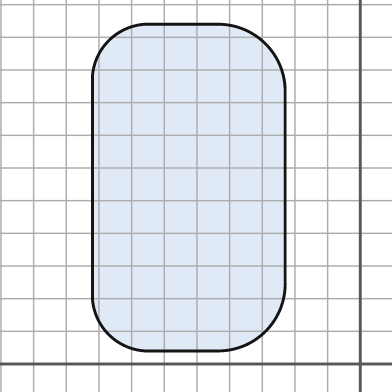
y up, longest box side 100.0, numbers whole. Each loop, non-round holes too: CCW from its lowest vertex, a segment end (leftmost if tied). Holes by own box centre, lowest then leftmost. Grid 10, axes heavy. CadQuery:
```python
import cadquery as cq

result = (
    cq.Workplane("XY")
    .moveTo(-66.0, 4.0)
    .lineTo(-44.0, 4.0)
    .threePointArc((-29.0, 10.0), (-23.0, 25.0))
    .lineTo(-23.0, 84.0)
    .threePointArc((-29.0, 98.0), (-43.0, 104.0))
    .lineTo(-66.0, 104.0)
    .threePointArc((-77.0, 99.0), (-82.0, 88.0))
    .lineTo(-82.0, 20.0)
    .threePointArc((-77.0, 9.0), (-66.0, 4.0))
    .close()
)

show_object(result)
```